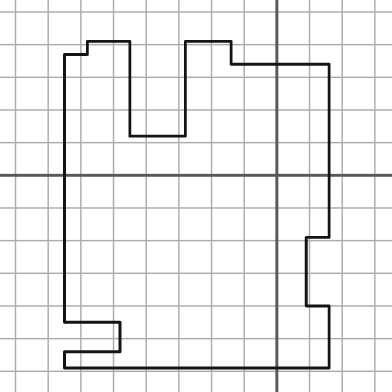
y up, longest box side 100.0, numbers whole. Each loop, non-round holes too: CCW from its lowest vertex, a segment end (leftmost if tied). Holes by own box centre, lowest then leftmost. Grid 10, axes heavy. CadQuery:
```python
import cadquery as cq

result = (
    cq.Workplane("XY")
    .moveTo(-65.0, -59.0)
    .lineTo(16.0, -59.0)
    .lineTo(16.0, -40.0)
    .lineTo(9.0, -40.0)
    .lineTo(9.0, -19.0)
    .lineTo(16.0, -19.0)
    .lineTo(16.0, 34.0)
    .lineTo(-14.0, 34.0)
    .lineTo(-14.0, 41.0)
    .lineTo(-28.0, 41.0)
    .lineTo(-28.0, 12.0)
    .lineTo(-45.0, 12.0)
    .lineTo(-45.0, 41.0)
    .lineTo(-58.0, 41.0)
    .lineTo(-58.0, 37.0)
    .lineTo(-65.0, 37.0)
    .lineTo(-65.0, -45.0)
    .lineTo(-48.0, -45.0)
    .lineTo(-48.0, -54.0)
    .lineTo(-65.0, -54.0)
    .close()
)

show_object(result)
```